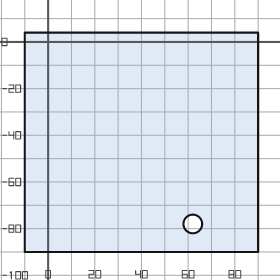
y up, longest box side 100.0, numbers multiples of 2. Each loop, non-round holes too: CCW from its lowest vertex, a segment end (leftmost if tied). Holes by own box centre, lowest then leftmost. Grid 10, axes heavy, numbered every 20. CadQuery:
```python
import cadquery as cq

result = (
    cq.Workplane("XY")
    .moveTo(-10.0, -90.0)
    .lineTo(90.0, -90.0)
    .lineTo(90.0, 4.0)
    .lineTo(-10.0, 4.0)
    .close()
    .moveTo(62.0, -78.0)
    .circle(4.0)
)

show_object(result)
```